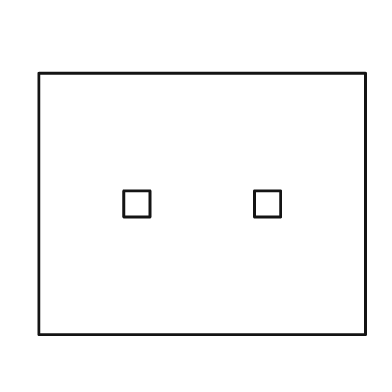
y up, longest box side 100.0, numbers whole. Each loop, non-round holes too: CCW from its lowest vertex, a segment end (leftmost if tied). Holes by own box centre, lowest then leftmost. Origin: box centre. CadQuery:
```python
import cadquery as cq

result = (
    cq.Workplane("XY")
    .moveTo(-50.0, -40.0)
    .lineTo(50.0, -40.0)
    .lineTo(50.0, 40.0)
    .lineTo(-50.0, 40.0)
    .close()
    .moveTo(-24.0, -4.0)
    .lineTo(-16.0, -4.0)
    .lineTo(-16.0, 4.0)
    .lineTo(-24.0, 4.0)
    .close()
    .moveTo(16.0, -4.0)
    .lineTo(24.0, -4.0)
    .lineTo(24.0, 4.0)
    .lineTo(16.0, 4.0)
    .close()
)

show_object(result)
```